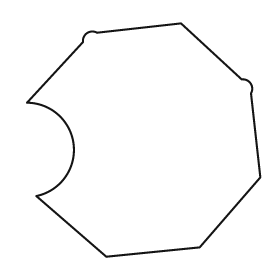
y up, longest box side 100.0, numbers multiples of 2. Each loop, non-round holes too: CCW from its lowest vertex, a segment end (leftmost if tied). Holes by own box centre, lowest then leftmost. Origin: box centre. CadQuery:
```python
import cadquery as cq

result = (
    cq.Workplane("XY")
    .moveTo(-16.0, -50.0)
    .lineTo(24.0, -46.0)
    .lineTo(50.0, -16.0)
    .lineTo(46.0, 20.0)
    .threePointArc((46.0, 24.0), (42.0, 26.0))
    .lineTo(16.0, 50.0)
    .lineTo(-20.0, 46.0)
    .threePointArc((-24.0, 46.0), (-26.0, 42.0))
    .lineTo(-50.0, 16.0)
    .threePointArc((-30.0, -2.0), (-46.0, -24.0))
    .close()
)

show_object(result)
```